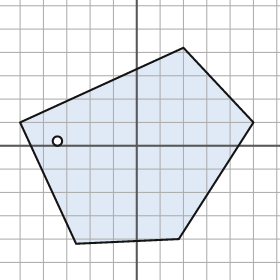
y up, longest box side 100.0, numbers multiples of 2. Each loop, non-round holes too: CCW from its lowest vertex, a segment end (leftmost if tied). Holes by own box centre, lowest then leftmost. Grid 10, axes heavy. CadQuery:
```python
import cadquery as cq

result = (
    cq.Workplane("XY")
    .moveTo(-26.0, -42.0)
    .lineTo(18.0, -40.0)
    .lineTo(50.0, 10.0)
    .lineTo(20.0, 42.0)
    .lineTo(-50.0, 10.0)
    .close()
    .moveTo(-34.0, 2.0)
    .circle(2.0)
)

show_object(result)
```